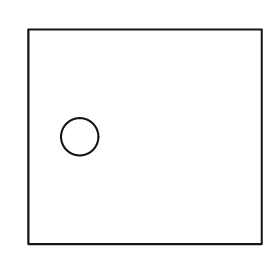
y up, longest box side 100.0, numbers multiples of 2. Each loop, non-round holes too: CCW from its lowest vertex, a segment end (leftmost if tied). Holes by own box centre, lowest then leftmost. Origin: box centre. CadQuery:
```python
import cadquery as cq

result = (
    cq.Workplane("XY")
    .moveTo(-50.0, -46.0)
    .lineTo(50.0, -46.0)
    .lineTo(50.0, 46.0)
    .lineTo(-50.0, 46.0)
    .close()
    .moveTo(-28.0, 0.0)
    .circle(8.0)
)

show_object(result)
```